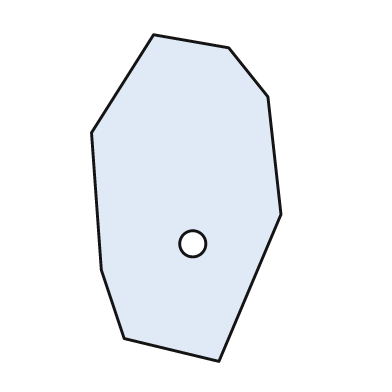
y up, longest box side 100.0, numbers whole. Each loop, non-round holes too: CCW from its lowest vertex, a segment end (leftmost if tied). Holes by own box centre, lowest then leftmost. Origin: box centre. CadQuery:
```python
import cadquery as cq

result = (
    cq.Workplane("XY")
    .moveTo(10.0, -50.0)
    .lineTo(29.0, -5.0)
    .lineTo(25.0, 31.0)
    .lineTo(13.0, 46.0)
    .lineTo(-10.0, 50.0)
    .lineTo(-29.0, 20.0)
    .lineTo(-26.0, -22.0)
    .lineTo(-19.0, -43.0)
    .close()
    .moveTo(2.0, -14.0)
    .circle(4.0)
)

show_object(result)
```